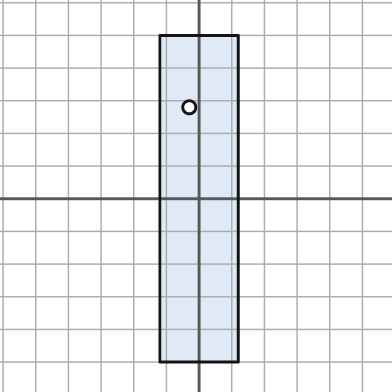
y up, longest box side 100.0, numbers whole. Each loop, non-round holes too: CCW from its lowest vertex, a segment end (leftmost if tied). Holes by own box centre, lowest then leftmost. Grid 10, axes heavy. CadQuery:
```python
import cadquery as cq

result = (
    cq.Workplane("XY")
    .moveTo(-12.0, -50.0)
    .lineTo(12.0, -50.0)
    .lineTo(12.0, 50.0)
    .lineTo(-12.0, 50.0)
    .close()
    .moveTo(-3.0, 28.0)
    .circle(2.0)
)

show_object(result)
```